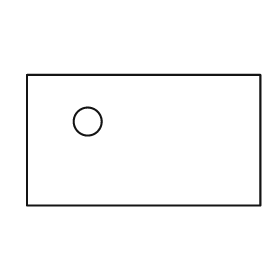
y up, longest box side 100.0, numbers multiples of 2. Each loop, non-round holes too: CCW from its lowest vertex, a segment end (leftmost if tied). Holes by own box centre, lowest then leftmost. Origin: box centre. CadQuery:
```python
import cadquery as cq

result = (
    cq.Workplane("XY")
    .moveTo(-50.0, -28.0)
    .lineTo(50.0, -28.0)
    .lineTo(50.0, 28.0)
    .lineTo(-50.0, 28.0)
    .close()
    .moveTo(-24.0, 8.0)
    .circle(6.0)
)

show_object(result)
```